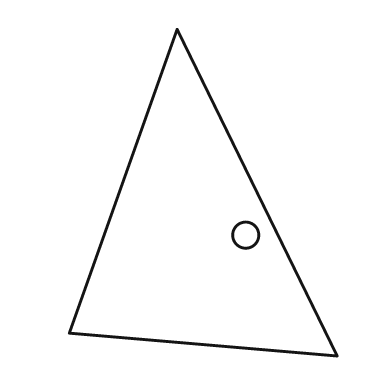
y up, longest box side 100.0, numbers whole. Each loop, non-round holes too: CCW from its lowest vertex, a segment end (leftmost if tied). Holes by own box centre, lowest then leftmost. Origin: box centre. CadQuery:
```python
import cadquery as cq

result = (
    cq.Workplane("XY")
    .moveTo(41.0, -50.0)
    .lineTo(-8.0, 50.0)
    .lineTo(-41.0, -43.0)
    .close()
    .moveTo(13.0, -13.0)
    .circle(4.0)
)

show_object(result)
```